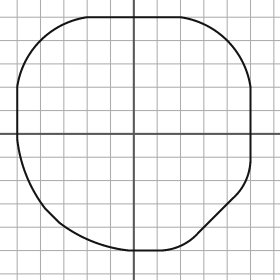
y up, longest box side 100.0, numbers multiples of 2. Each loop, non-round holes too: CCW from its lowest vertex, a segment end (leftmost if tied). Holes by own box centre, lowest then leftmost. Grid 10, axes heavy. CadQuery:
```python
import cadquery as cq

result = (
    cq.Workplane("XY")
    .moveTo(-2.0, -50.0)
    .lineTo(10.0, -50.0)
    .threePointArc((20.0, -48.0), (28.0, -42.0))
    .lineTo(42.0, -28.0)
    .threePointArc((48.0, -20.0), (50.0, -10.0))
    .lineTo(50.0, 20.0)
    .threePointArc((40.0, 40.0), (20.0, 50.0))
    .lineTo(-20.0, 50.0)
    .threePointArc((-40.0, 40.0), (-50.0, 20.0))
    .lineTo(-50.0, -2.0)
    .threePointArc((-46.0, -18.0), (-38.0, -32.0))
    .lineTo(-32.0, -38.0)
    .threePointArc((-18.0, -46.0), (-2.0, -50.0))
    .close()
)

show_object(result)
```